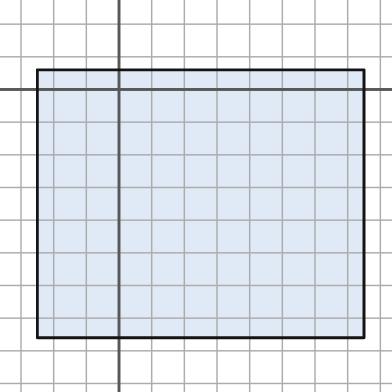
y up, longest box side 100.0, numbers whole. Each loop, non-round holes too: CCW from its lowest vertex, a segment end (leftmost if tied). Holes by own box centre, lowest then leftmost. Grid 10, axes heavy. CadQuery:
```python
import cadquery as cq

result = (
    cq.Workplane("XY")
    .moveTo(-25.0, -76.0)
    .lineTo(75.0, -76.0)
    .lineTo(75.0, 6.0)
    .lineTo(-25.0, 6.0)
    .close()
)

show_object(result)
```